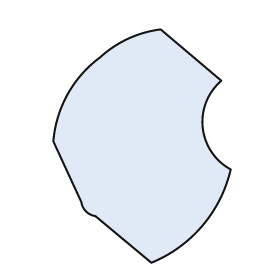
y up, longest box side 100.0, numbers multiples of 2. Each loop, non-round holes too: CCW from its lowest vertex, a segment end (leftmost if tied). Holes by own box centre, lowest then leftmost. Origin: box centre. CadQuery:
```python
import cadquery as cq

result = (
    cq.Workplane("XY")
    .moveTo(4.0, -50.0)
    .threePointArc((26.0, -34.0), (38.0, -10.0))
    .threePointArc((26.0, 8.0), (34.0, 28.0))
    .lineTo(8.0, 50.0)
    .threePointArc((-6.0, 46.0), (-18.0, 38.0))
    .threePointArc((-32.0, 22.0), (-38.0, 2.0))
    .lineTo(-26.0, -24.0)
    .threePointArc((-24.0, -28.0), (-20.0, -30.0))
    .close()
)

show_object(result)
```